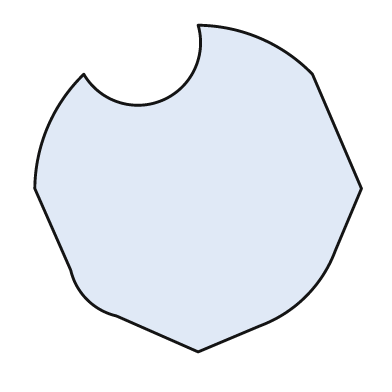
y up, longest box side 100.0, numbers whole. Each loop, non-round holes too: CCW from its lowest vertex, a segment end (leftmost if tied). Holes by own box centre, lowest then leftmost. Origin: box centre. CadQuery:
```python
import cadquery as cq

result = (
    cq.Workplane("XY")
    .moveTo(0.0, -50.0)
    .lineTo(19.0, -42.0)
    .threePointArc((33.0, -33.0), (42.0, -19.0))
    .lineTo(50.0, 0.0)
    .lineTo(35.0, 35.0)
    .threePointArc((19.0, 46.0), (0.0, 50.0))
    .threePointArc((-11.0, 27.0), (-35.0, 35.0))
    .threePointArc((-46.0, 19.0), (-50.0, 0.0))
    .lineTo(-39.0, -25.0)
    .threePointArc((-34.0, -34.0), (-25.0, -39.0))
    .close()
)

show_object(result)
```